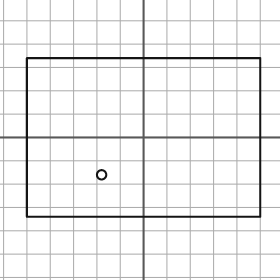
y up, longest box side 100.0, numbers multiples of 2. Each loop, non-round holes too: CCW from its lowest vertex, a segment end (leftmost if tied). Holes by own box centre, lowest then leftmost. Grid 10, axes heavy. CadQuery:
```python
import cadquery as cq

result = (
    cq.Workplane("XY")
    .moveTo(-50.0, -34.0)
    .lineTo(50.0, -34.0)
    .lineTo(50.0, 34.0)
    .lineTo(-50.0, 34.0)
    .close()
    .moveTo(-18.0, -16.0)
    .circle(2.0)
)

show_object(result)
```